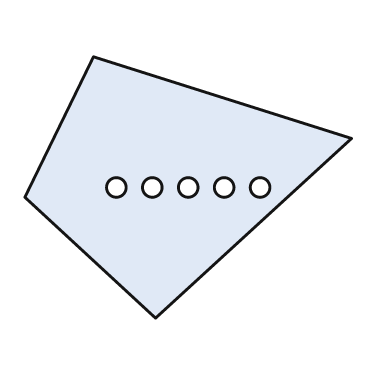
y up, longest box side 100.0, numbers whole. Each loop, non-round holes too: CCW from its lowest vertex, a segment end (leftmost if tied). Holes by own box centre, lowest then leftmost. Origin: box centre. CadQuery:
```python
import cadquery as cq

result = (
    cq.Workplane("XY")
    .moveTo(-10.0, -40.0)
    .lineTo(50.0, 15.0)
    .lineTo(-29.0, 40.0)
    .lineTo(-50.0, -3.0)
    .close()
    .moveTo(-22.0, 0.0)
    .circle(3.0)
    .moveTo(-11.0, 0.0)
    .circle(3.0)
    .moveTo(0.0, 0.0)
    .circle(3.0)
    .moveTo(11.0, 0.0)
    .circle(3.0)
    .moveTo(22.0, 0.0)
    .circle(3.0)
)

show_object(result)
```